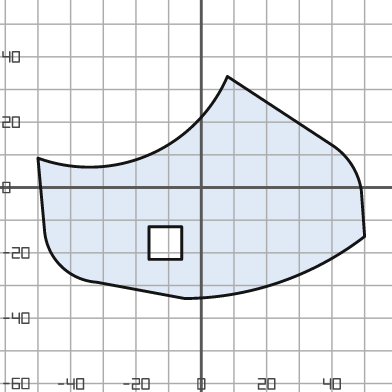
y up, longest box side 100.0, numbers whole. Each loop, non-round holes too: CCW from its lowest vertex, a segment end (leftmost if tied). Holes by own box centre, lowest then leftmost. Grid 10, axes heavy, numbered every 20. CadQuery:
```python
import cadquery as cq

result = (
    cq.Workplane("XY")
    .moveTo(-5.0, -34.0)
    .threePointArc((24.0, -29.0), (50.0, -15.0))
    .lineTo(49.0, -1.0)
    .threePointArc((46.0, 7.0), (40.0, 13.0))
    .lineTo(8.0, 34.0)
    .threePointArc((-16.0, 10.0), (-50.0, 9.0))
    .lineTo(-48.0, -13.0)
    .threePointArc((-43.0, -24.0), (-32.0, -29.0))
    .close()
    .moveTo(-16.0, -22.0)
    .lineTo(-6.0, -22.0)
    .lineTo(-6.0, -12.0)
    .lineTo(-16.0, -12.0)
    .close()
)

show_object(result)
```